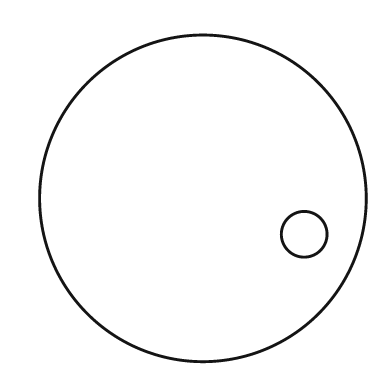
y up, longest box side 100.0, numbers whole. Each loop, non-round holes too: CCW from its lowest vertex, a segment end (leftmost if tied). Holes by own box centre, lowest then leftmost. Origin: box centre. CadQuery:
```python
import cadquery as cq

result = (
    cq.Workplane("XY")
    .moveTo(0.0, 0.0)
    .circle(50.0)
    .moveTo(31.0, -11.0)
    .circle(7.0)
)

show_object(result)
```